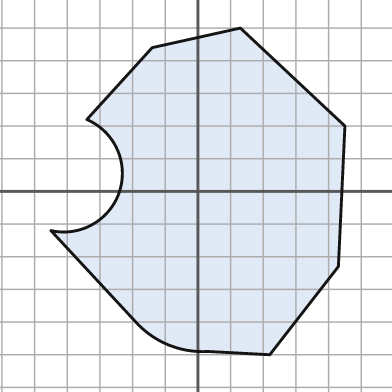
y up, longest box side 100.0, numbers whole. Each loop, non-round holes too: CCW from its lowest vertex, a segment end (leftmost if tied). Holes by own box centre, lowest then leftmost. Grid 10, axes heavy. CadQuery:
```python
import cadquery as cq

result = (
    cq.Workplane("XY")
    .moveTo(22.0, -50.0)
    .lineTo(43.0, -23.0)
    .lineTo(45.0, 20.0)
    .lineTo(13.0, 50.0)
    .lineTo(-14.0, 44.0)
    .lineTo(-34.0, 22.0)
    .threePointArc((-24.0, 0.0), (-45.0, -12.0))
    .lineTo(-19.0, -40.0)
    .threePointArc((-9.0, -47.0), (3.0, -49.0))
    .close()
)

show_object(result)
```